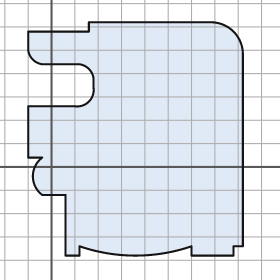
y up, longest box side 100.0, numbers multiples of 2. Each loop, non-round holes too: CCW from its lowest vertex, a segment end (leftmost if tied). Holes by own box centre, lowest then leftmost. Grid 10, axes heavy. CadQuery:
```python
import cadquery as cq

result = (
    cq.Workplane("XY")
    .moveTo(6.0, -38.0)
    .lineTo(12.0, -38.0)
    .lineTo(12.0, -34.0)
    .threePointArc((36.0, -38.0), (60.0, -34.0))
    .lineTo(60.0, -38.0)
    .lineTo(78.0, -38.0)
    .lineTo(78.0, -34.0)
    .lineTo(82.0, -34.0)
    .lineTo(82.0, 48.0)
    .threePointArc((78.0, 58.0), (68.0, 62.0))
    .lineTo(16.0, 62.0)
    .lineTo(16.0, 58.0)
    .lineTo(-10.0, 58.0)
    .lineTo(-10.0, 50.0)
    .threePointArc((-8.0, 46.0), (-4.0, 44.0))
    .lineTo(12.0, 44.0)
    .threePointArc((16.0, 42.0), (18.0, 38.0))
    .lineTo(18.0, 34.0)
    .threePointArc((16.0, 28.0), (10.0, 26.0))
    .lineTo(-10.0, 26.0)
    .lineTo(-10.0, 4.0)
    .lineTo(-4.0, 4.0)
    .threePointArc((-8.0, -4.0), (-4.0, -12.0))
    .lineTo(6.0, -12.0)
    .close()
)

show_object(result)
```